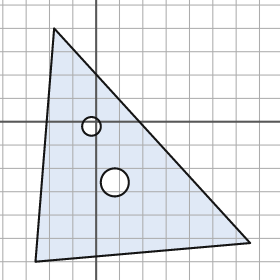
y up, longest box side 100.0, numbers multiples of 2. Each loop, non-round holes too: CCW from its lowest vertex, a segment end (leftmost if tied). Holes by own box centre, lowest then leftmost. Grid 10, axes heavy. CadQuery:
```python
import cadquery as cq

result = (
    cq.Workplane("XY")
    .moveTo(-26.0, -60.0)
    .lineTo(66.0, -52.0)
    .lineTo(-18.0, 40.0)
    .close()
    .moveTo(8.0, -26.0)
    .circle(6.0)
    .moveTo(-2.0, -2.0)
    .circle(4.0)
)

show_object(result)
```